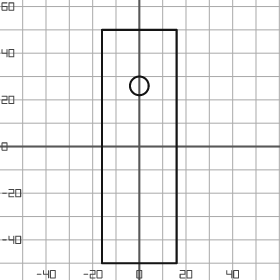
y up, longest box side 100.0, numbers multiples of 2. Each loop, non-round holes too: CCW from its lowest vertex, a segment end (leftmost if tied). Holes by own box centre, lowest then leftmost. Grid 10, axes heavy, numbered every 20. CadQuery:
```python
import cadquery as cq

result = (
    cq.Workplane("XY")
    .moveTo(-16.0, -50.0)
    .lineTo(16.0, -50.0)
    .lineTo(16.0, 50.0)
    .lineTo(-16.0, 50.0)
    .close()
    .moveTo(0.0, 26.0)
    .circle(4.0)
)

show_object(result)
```